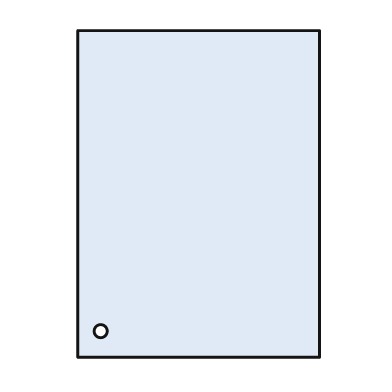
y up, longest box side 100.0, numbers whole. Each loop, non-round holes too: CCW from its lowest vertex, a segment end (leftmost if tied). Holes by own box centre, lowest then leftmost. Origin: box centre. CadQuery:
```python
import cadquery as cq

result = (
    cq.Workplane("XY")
    .moveTo(-37.0, -50.0)
    .lineTo(37.0, -50.0)
    .lineTo(37.0, 50.0)
    .lineTo(-37.0, 50.0)
    .close()
    .moveTo(-30.0, -42.0)
    .circle(2.0)
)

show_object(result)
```